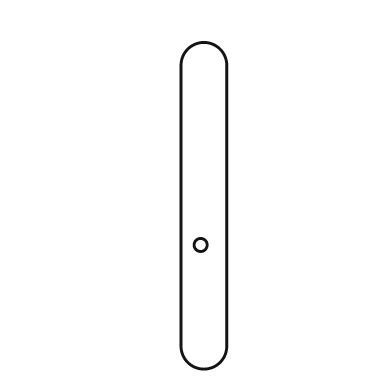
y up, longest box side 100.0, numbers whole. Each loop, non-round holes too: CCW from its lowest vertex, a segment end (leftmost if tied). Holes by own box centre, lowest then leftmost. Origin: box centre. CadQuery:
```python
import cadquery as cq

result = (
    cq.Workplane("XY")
    .moveTo(-7.0, -43.0)
    .threePointArc((0.0, -50.0), (7.0, -43.0))
    .lineTo(7.0, 43.0)
    .threePointArc((0.0, 50.0), (-7.0, 43.0))
    .close()
    .moveTo(-1.0, -12.0)
    .circle(2.0)
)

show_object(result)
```